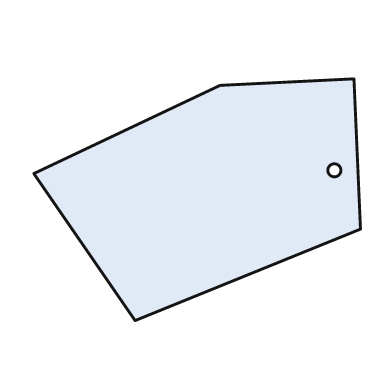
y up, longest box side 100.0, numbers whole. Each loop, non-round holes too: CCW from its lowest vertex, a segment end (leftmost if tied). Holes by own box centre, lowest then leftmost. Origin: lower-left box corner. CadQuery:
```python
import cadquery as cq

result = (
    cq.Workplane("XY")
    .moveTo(31.0, 0.0)
    .lineTo(100.0, 28.0)
    .lineTo(98.0, 74.0)
    .lineTo(57.0, 72.0)
    .lineTo(0.0, 45.0)
    .close()
    .moveTo(92.0, 46.0)
    .circle(2.0)
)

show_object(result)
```